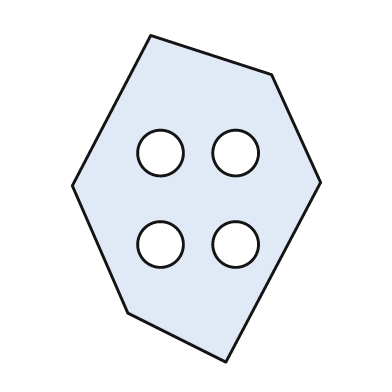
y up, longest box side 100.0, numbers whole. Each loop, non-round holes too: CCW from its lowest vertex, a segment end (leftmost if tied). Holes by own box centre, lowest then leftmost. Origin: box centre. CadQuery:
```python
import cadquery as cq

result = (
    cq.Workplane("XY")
    .moveTo(9.0, -50.0)
    .lineTo(38.0, 5.0)
    .lineTo(23.0, 38.0)
    .lineTo(-14.0, 50.0)
    .lineTo(-38.0, 4.0)
    .lineTo(-21.0, -35.0)
    .close()
    .moveTo(-11.0, -14.0)
    .circle(7.0)
    .moveTo(12.0, -14.0)
    .circle(7.0)
    .moveTo(-11.0, 14.0)
    .circle(7.0)
    .moveTo(12.0, 14.0)
    .circle(7.0)
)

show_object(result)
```